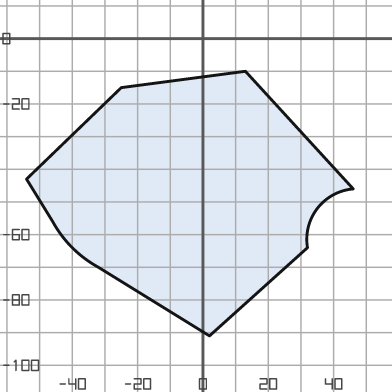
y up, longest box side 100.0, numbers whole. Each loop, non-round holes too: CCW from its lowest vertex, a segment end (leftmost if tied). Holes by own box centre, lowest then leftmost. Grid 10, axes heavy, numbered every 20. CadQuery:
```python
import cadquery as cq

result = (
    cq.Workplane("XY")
    .moveTo(2.0, -91.0)
    .lineTo(32.0, -64.0)
    .threePointArc((35.0, -52.0), (46.0, -46.0))
    .lineTo(13.0, -10.0)
    .lineTo(-25.0, -15.0)
    .lineTo(-54.0, -43.0)
    .lineTo(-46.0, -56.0)
    .threePointArc((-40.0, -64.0), (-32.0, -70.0))
    .close()
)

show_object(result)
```